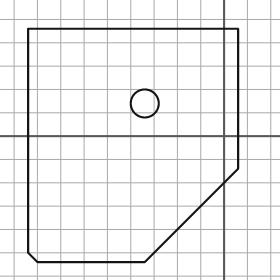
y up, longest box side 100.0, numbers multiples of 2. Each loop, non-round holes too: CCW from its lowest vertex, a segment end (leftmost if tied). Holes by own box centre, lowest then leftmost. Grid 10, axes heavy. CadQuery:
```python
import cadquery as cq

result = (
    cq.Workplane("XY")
    .moveTo(-80.0, -54.0)
    .lineTo(-34.0, -54.0)
    .lineTo(6.0, -14.0)
    .lineTo(6.0, 46.0)
    .lineTo(-84.0, 46.0)
    .lineTo(-84.0, -50.0)
    .close()
    .moveTo(-34.0, 14.0)
    .circle(6.0)
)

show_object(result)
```